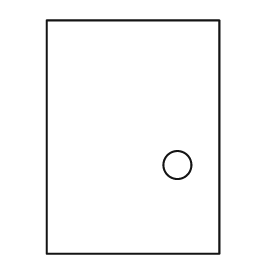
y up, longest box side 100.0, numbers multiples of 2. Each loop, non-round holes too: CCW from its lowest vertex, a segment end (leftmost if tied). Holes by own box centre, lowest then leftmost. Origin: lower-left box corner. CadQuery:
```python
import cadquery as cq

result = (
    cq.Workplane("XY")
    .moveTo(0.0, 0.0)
    .lineTo(74.0, 0.0)
    .lineTo(74.0, 100.0)
    .lineTo(0.0, 100.0)
    .close()
    .moveTo(56.0, 38.0)
    .circle(6.0)
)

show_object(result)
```